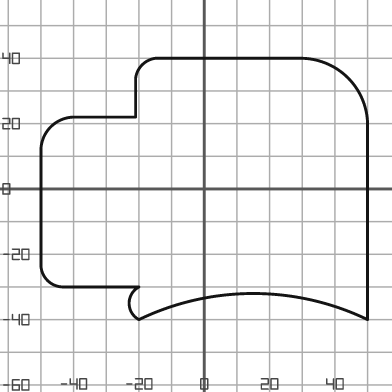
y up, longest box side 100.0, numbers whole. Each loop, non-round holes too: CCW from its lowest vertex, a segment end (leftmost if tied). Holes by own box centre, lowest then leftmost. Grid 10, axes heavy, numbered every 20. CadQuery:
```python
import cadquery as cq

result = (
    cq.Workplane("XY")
    .moveTo(-20.0, -40.0)
    .threePointArc((15.0, -32.0), (50.0, -40.0))
    .lineTo(50.0, 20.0)
    .threePointArc((44.0, 34.0), (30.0, 40.0))
    .lineTo(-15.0, 40.0)
    .threePointArc((-19.0, 38.0), (-21.0, 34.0))
    .lineTo(-21.0, 22.0)
    .lineTo(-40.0, 22.0)
    .threePointArc((-47.0, 19.0), (-50.0, 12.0))
    .lineTo(-50.0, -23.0)
    .threePointArc((-48.0, -28.0), (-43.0, -30.0))
    .lineTo(-20.0, -30.0)
    .threePointArc((-23.0, -35.0), (-20.0, -40.0))
    .close()
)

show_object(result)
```